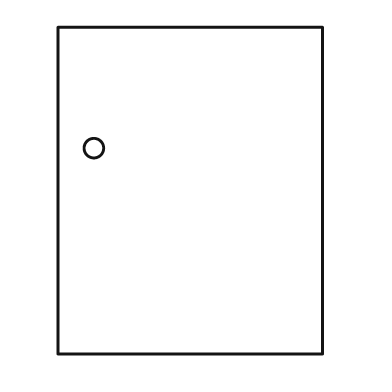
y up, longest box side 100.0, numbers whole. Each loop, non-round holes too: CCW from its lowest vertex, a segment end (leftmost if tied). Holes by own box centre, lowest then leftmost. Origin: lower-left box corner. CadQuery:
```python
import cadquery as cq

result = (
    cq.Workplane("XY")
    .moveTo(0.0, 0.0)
    .lineTo(81.0, 0.0)
    .lineTo(81.0, 100.0)
    .lineTo(0.0, 100.0)
    .close()
    .moveTo(11.0, 63.0)
    .circle(3.0)
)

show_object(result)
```